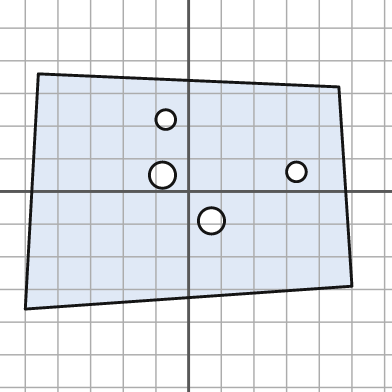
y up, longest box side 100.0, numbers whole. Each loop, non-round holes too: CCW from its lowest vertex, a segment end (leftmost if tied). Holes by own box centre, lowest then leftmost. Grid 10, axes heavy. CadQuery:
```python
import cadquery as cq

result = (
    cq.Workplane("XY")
    .moveTo(-50.0, -36.0)
    .lineTo(50.0, -29.0)
    .lineTo(46.0, 32.0)
    .lineTo(-46.0, 36.0)
    .close()
    .moveTo(7.0, -9.0)
    .circle(4.0)
    .moveTo(-8.0, 5.0)
    .circle(4.0)
    .moveTo(33.0, 6.0)
    .circle(3.0)
    .moveTo(-7.0, 22.0)
    .circle(3.0)
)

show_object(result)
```